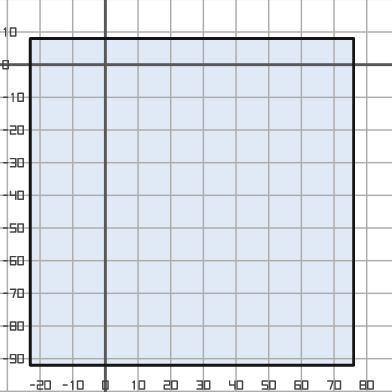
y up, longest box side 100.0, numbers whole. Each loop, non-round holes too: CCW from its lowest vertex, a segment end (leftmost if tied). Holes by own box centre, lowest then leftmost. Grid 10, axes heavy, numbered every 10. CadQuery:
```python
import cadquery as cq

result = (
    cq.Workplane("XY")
    .moveTo(-23.0, -92.0)
    .lineTo(76.0, -92.0)
    .lineTo(76.0, 8.0)
    .lineTo(-23.0, 8.0)
    .close()
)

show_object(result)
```